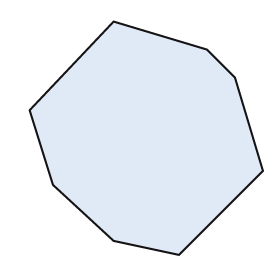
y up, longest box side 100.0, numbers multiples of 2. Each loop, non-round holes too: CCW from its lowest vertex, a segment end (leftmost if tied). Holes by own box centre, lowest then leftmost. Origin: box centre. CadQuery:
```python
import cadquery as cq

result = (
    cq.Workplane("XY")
    .moveTo(14.0, -50.0)
    .lineTo(50.0, -14.0)
    .lineTo(38.0, 26.0)
    .lineTo(26.0, 38.0)
    .lineTo(-14.0, 50.0)
    .lineTo(-50.0, 12.0)
    .lineTo(-40.0, -20.0)
    .lineTo(-14.0, -44.0)
    .close()
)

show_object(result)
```